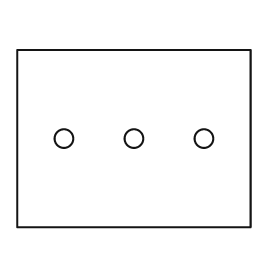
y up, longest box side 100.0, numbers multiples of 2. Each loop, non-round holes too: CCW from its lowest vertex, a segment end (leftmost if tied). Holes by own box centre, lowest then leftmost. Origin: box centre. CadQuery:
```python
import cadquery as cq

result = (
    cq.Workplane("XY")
    .moveTo(-50.0, -38.0)
    .lineTo(50.0, -38.0)
    .lineTo(50.0, 38.0)
    .lineTo(-50.0, 38.0)
    .close()
    .moveTo(-30.0, 0.0)
    .circle(4.0)
    .moveTo(0.0, 0.0)
    .circle(4.0)
    .moveTo(30.0, 0.0)
    .circle(4.0)
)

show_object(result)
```